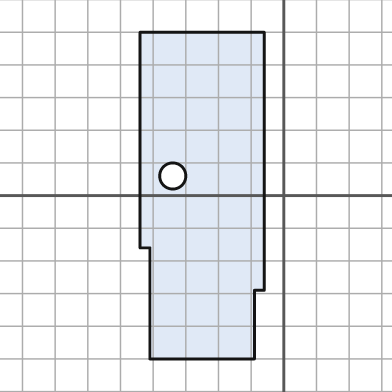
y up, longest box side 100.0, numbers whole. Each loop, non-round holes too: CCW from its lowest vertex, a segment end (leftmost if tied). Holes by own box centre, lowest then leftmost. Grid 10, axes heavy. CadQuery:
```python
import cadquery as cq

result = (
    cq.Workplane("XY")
    .moveTo(-41.0, -50.0)
    .lineTo(-9.0, -50.0)
    .lineTo(-9.0, -29.0)
    .lineTo(-6.0, -29.0)
    .lineTo(-6.0, 50.0)
    .lineTo(-44.0, 50.0)
    .lineTo(-44.0, -16.0)
    .lineTo(-41.0, -16.0)
    .close()
    .moveTo(-34.0, 6.0)
    .circle(4.0)
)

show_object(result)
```